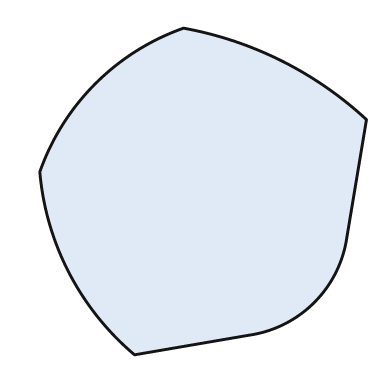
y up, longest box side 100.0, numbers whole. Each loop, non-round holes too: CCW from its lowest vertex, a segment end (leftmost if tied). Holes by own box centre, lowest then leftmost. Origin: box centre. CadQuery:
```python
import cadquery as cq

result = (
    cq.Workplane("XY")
    .moveTo(-21.0, -50.0)
    .lineTo(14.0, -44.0)
    .threePointArc((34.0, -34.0), (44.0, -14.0))
    .lineTo(50.0, 22.0)
    .threePointArc((24.0, 40.0), (-6.0, 50.0))
    .threePointArc((-33.0, 33.0), (-50.0, 6.0))
    .threePointArc((-41.0, -25.0), (-21.0, -50.0))
    .close()
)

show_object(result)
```